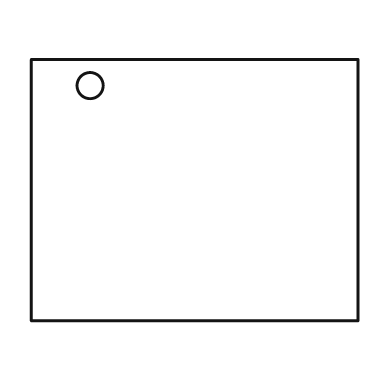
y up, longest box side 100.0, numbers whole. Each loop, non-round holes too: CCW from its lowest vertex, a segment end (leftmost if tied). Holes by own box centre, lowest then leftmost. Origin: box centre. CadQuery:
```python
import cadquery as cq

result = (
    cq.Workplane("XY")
    .moveTo(-50.0, -40.0)
    .lineTo(50.0, -40.0)
    .lineTo(50.0, 40.0)
    .lineTo(-50.0, 40.0)
    .close()
    .moveTo(-32.0, 32.0)
    .circle(4.0)
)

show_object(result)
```